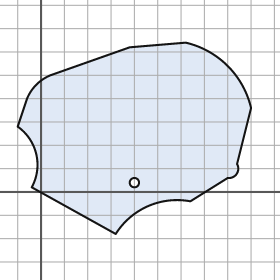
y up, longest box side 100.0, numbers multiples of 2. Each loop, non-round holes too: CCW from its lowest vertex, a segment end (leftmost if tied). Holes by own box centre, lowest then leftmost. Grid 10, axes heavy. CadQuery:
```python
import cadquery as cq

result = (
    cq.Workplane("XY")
    .moveTo(32.0, -18.0)
    .threePointArc((46.0, -6.0), (64.0, -4.0))
    .lineTo(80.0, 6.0)
    .threePointArc((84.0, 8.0), (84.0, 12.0))
    .lineTo(90.0, 36.0)
    .threePointArc((80.0, 54.0), (62.0, 64.0))
    .lineTo(38.0, 62.0)
    .lineTo(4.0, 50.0)
    .threePointArc((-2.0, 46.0), (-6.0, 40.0))
    .lineTo(-10.0, 28.0)
    .threePointArc((-2.0, 16.0), (-4.0, 2.0))
    .close()
    .moveTo(40.0, 4.0)
    .circle(2.0)
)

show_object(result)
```